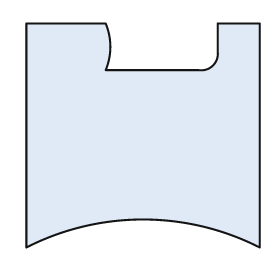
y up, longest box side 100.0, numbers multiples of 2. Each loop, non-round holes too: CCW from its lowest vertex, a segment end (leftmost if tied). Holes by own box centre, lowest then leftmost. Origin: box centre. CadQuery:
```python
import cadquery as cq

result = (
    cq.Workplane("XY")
    .moveTo(-50.0, -48.0)
    .threePointArc((0.0, -36.0), (50.0, -48.0))
    .lineTo(50.0, 48.0)
    .lineTo(32.0, 48.0)
    .lineTo(32.0, 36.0)
    .threePointArc((30.0, 30.0), (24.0, 28.0))
    .lineTo(-16.0, 28.0)
    .threePointArc((-14.0, 38.0), (-16.0, 48.0))
    .lineTo(-50.0, 48.0)
    .close()
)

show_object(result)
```